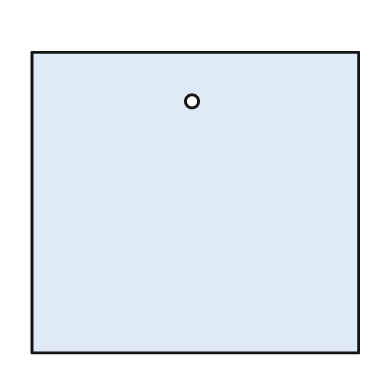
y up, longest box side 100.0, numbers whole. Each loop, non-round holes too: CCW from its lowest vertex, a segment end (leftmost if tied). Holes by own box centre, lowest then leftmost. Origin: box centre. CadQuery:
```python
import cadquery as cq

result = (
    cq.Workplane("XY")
    .moveTo(-50.0, -46.0)
    .lineTo(50.0, -46.0)
    .lineTo(50.0, 46.0)
    .lineTo(-50.0, 46.0)
    .close()
    .moveTo(-1.0, 31.0)
    .circle(2.0)
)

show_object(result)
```